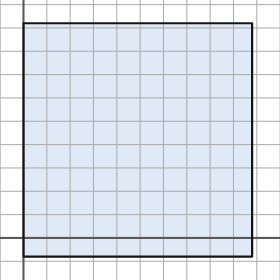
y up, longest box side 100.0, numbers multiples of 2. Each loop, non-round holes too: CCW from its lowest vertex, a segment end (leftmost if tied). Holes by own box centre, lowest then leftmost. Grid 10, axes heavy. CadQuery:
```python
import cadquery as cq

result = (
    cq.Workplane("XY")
    .moveTo(0.0, -8.0)
    .lineTo(98.0, -8.0)
    .lineTo(98.0, 92.0)
    .lineTo(0.0, 92.0)
    .close()
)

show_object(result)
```